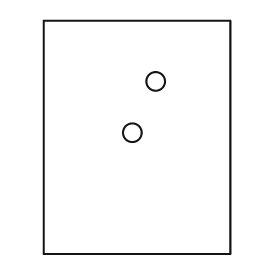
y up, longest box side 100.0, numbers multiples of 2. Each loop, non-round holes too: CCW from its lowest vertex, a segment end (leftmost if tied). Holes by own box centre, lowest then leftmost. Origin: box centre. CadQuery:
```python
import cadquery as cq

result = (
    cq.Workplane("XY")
    .moveTo(-40.0, -50.0)
    .lineTo(40.0, -50.0)
    .lineTo(40.0, 50.0)
    .lineTo(-40.0, 50.0)
    .close()
    .moveTo(-2.0, 2.0)
    .circle(4.0)
    .moveTo(8.0, 24.0)
    .circle(4.0)
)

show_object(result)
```